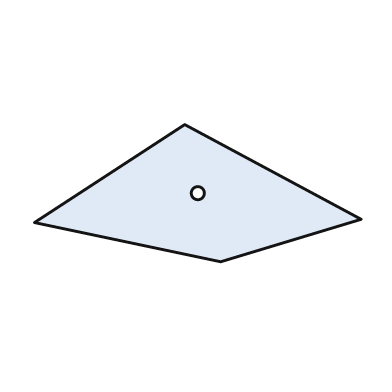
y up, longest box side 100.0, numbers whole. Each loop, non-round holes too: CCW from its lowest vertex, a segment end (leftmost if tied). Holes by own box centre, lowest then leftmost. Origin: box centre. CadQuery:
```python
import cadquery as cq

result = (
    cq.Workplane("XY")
    .moveTo(7.0, -21.0)
    .lineTo(50.0, -8.0)
    .lineTo(-4.0, 21.0)
    .lineTo(-50.0, -9.0)
    .close()
    .moveTo(0.0, 0.0)
    .circle(2.0)
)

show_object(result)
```